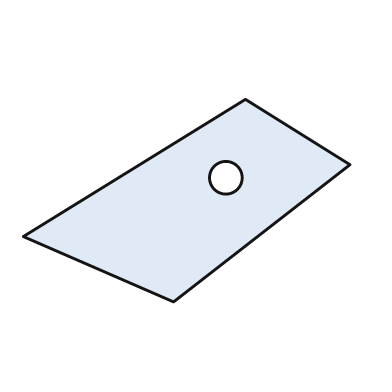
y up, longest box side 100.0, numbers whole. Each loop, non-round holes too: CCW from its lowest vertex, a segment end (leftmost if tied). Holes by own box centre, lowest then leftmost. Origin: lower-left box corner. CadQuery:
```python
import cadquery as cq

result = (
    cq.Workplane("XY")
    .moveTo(46.0, 0.0)
    .lineTo(100.0, 42.0)
    .lineTo(68.0, 62.0)
    .lineTo(0.0, 20.0)
    .close()
    .moveTo(62.0, 38.0)
    .circle(5.0)
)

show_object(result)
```